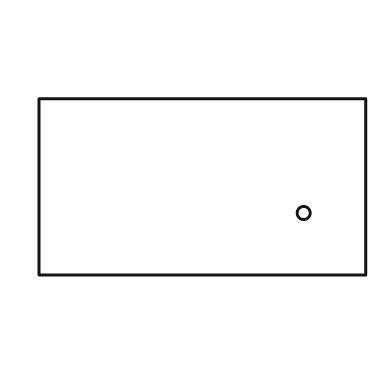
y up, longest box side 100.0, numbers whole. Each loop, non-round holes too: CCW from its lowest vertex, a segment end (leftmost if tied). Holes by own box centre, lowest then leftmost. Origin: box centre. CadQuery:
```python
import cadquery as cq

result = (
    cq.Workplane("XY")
    .moveTo(-50.0, -27.0)
    .lineTo(50.0, -27.0)
    .lineTo(50.0, 27.0)
    .lineTo(-50.0, 27.0)
    .close()
    .moveTo(31.0, -8.0)
    .circle(2.0)
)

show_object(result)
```